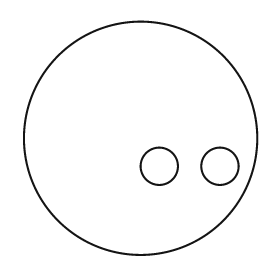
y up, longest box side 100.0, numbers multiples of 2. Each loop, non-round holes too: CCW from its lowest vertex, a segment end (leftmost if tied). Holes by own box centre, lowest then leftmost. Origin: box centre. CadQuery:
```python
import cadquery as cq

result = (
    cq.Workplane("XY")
    .moveTo(0.0, 0.0)
    .circle(50.0)
    .moveTo(8.0, -12.0)
    .circle(8.0)
    .moveTo(34.0, -12.0)
    .circle(8.0)
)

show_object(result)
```